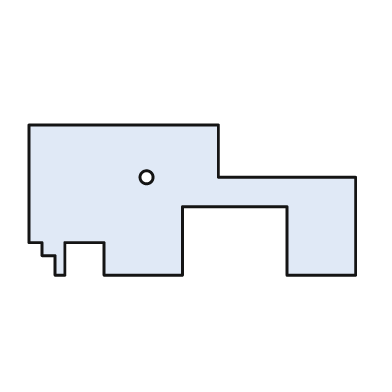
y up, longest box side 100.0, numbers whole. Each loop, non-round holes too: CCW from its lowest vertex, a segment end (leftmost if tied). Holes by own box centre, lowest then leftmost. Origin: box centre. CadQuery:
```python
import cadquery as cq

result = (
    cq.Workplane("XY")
    .moveTo(-42.0, -23.0)
    .lineTo(-39.0, -23.0)
    .lineTo(-39.0, -13.0)
    .lineTo(-27.0, -13.0)
    .lineTo(-27.0, -23.0)
    .lineTo(-3.0, -23.0)
    .lineTo(-3.0, -2.0)
    .lineTo(29.0, -2.0)
    .lineTo(29.0, -23.0)
    .lineTo(50.0, -23.0)
    .lineTo(50.0, 7.0)
    .lineTo(8.0, 7.0)
    .lineTo(8.0, 23.0)
    .lineTo(-50.0, 23.0)
    .lineTo(-50.0, -13.0)
    .lineTo(-46.0, -13.0)
    .lineTo(-46.0, -17.0)
    .lineTo(-42.0, -17.0)
    .close()
    .moveTo(-14.0, 7.0)
    .circle(2.0)
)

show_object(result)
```